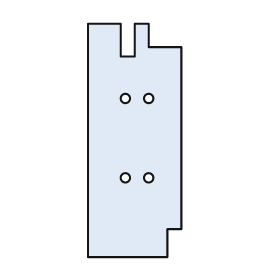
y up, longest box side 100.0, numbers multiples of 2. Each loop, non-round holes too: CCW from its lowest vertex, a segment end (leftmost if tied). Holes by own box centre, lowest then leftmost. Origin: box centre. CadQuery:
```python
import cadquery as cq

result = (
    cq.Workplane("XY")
    .moveTo(-20.0, -50.0)
    .lineTo(14.0, -50.0)
    .lineTo(14.0, -38.0)
    .lineTo(20.0, -38.0)
    .lineTo(20.0, 40.0)
    .lineTo(6.0, 40.0)
    .lineTo(6.0, 50.0)
    .lineTo(0.0, 50.0)
    .lineTo(0.0, 36.0)
    .lineTo(-6.0, 36.0)
    .lineTo(-6.0, 50.0)
    .lineTo(-20.0, 50.0)
    .close()
    .moveTo(-4.0, -16.0)
    .circle(2.0)
    .moveTo(6.0, -16.0)
    .circle(2.0)
    .moveTo(-4.0, 18.0)
    .circle(2.0)
    .moveTo(6.0, 18.0)
    .circle(2.0)
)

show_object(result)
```